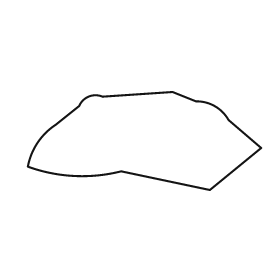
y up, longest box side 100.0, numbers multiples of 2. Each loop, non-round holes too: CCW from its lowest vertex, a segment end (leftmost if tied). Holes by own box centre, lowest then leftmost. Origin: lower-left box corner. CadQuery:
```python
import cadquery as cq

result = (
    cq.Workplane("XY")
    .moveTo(78.0, 0.0)
    .lineTo(100.0, 18.0)
    .lineTo(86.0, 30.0)
    .threePointArc((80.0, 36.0), (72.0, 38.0))
    .lineTo(62.0, 42.0)
    .lineTo(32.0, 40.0)
    .threePointArc((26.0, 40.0), (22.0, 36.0))
    .lineTo(12.0, 28.0)
    .threePointArc((4.0, 20.0), (0.0, 10.0))
    .threePointArc((20.0, 6.0), (40.0, 8.0))
    .close()
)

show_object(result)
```